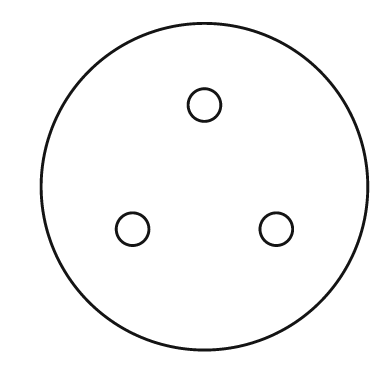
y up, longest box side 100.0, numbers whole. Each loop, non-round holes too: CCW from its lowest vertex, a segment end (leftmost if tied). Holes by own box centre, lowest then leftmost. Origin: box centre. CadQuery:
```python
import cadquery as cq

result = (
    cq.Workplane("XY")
    .moveTo(0.0, 0.0)
    .circle(50.0)
    .moveTo(-22.0, -13.0)
    .circle(5.0)
    .moveTo(22.0, -13.0)
    .circle(5.0)
    .moveTo(0.0, 25.0)
    .circle(5.0)
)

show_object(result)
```